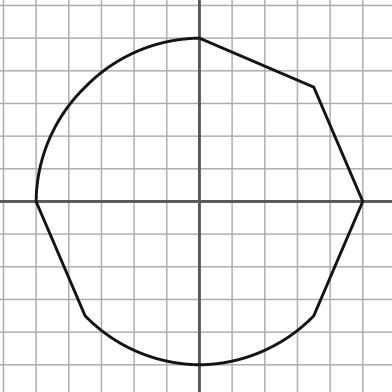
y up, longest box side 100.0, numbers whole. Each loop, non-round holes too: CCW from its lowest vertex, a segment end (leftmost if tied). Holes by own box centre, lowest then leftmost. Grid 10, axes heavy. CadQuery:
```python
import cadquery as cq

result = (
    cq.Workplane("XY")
    .moveTo(0.0, -50.0)
    .threePointArc((19.0, -46.0), (35.0, -35.0))
    .lineTo(50.0, 0.0)
    .lineTo(35.0, 35.0)
    .lineTo(0.0, 50.0)
    .threePointArc((-19.0, 46.0), (-35.0, 35.0))
    .threePointArc((-46.0, 19.0), (-50.0, 0.0))
    .lineTo(-35.0, -35.0)
    .threePointArc((-19.0, -46.0), (0.0, -50.0))
    .close()
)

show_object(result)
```